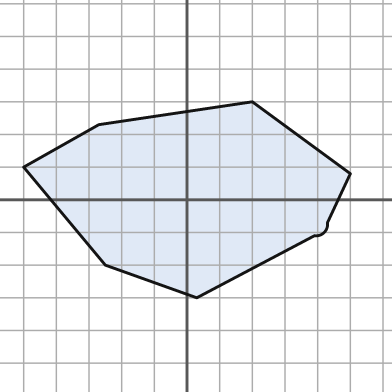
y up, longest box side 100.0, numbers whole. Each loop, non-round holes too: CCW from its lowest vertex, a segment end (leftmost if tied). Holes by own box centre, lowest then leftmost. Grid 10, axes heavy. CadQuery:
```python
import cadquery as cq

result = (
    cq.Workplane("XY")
    .moveTo(3.0, -30.0)
    .lineTo(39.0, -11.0)
    .threePointArc((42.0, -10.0), (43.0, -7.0))
    .lineTo(50.0, 8.0)
    .lineTo(20.0, 30.0)
    .lineTo(-27.0, 23.0)
    .lineTo(-50.0, 10.0)
    .lineTo(-25.0, -20.0)
    .close()
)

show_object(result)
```